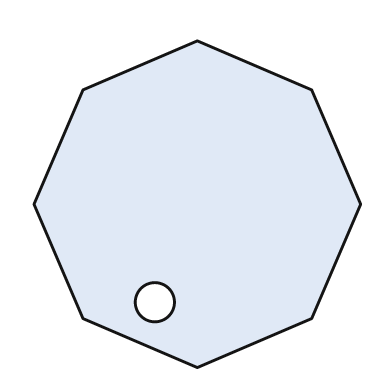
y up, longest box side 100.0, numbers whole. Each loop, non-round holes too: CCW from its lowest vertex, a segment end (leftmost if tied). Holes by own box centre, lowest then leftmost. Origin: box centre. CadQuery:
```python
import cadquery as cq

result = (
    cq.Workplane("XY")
    .moveTo(0.0, -50.0)
    .lineTo(35.0, -35.0)
    .lineTo(50.0, 0.0)
    .lineTo(35.0, 35.0)
    .lineTo(0.0, 50.0)
    .lineTo(-35.0, 35.0)
    .lineTo(-50.0, 0.0)
    .lineTo(-35.0, -35.0)
    .close()
    .moveTo(-13.0, -30.0)
    .circle(6.0)
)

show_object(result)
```